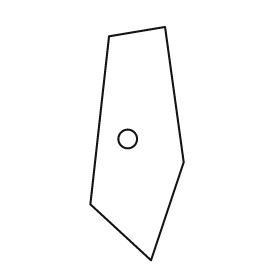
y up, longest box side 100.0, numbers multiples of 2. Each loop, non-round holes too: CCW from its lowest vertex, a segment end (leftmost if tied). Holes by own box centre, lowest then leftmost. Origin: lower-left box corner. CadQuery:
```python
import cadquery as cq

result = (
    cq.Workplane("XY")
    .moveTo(26.0, 0.0)
    .lineTo(40.0, 42.0)
    .lineTo(32.0, 100.0)
    .lineTo(8.0, 96.0)
    .lineTo(0.0, 24.0)
    .close()
    .moveTo(16.0, 52.0)
    .circle(4.0)
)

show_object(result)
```